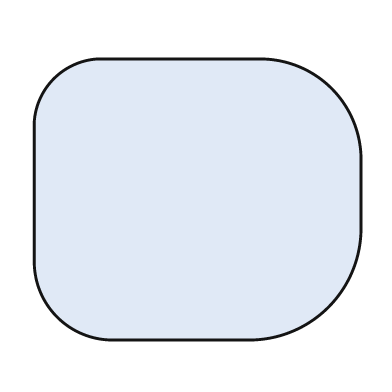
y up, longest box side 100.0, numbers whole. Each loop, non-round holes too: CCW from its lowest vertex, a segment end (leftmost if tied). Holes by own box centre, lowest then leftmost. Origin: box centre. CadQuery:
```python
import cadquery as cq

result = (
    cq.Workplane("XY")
    .moveTo(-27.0, -43.0)
    .lineTo(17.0, -43.0)
    .threePointArc((40.0, -33.0), (50.0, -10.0))
    .lineTo(50.0, 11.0)
    .threePointArc((41.0, 34.0), (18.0, 43.0))
    .lineTo(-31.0, 43.0)
    .threePointArc((-44.0, 37.0), (-50.0, 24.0))
    .lineTo(-50.0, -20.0)
    .threePointArc((-43.0, -36.0), (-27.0, -43.0))
    .close()
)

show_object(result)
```